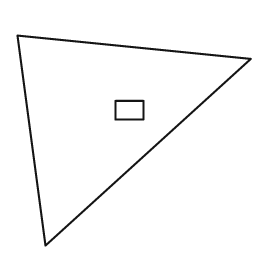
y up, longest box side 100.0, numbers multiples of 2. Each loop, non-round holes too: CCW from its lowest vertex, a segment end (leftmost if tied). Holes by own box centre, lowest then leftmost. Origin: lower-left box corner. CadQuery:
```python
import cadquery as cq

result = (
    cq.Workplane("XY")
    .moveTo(12.0, 0.0)
    .lineTo(100.0, 80.0)
    .lineTo(0.0, 90.0)
    .close()
    .moveTo(42.0, 54.0)
    .lineTo(54.0, 54.0)
    .lineTo(54.0, 62.0)
    .lineTo(42.0, 62.0)
    .close()
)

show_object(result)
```